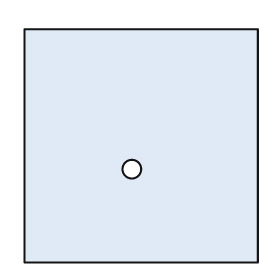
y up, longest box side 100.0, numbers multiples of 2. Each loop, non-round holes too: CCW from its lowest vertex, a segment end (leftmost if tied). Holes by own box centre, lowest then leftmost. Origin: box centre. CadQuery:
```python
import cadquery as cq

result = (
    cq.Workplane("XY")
    .moveTo(-50.0, -50.0)
    .lineTo(50.0, -50.0)
    .lineTo(50.0, 50.0)
    .lineTo(-50.0, 50.0)
    .close()
    .moveTo(-4.0, -10.0)
    .circle(4.0)
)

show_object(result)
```